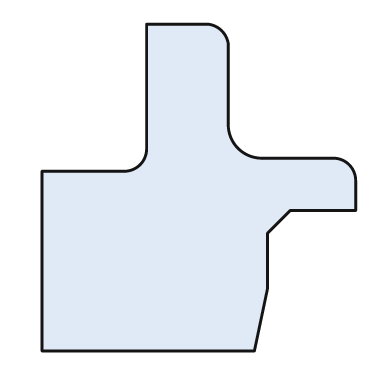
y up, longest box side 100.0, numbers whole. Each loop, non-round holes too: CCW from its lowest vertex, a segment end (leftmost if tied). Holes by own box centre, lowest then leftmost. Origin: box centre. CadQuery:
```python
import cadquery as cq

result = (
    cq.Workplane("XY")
    .moveTo(-48.0, -50.0)
    .lineTo(17.0, -50.0)
    .lineTo(21.0, -31.0)
    .lineTo(21.0, -14.0)
    .lineTo(28.0, -7.0)
    .lineTo(48.0, -7.0)
    .lineTo(48.0, 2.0)
    .threePointArc((46.0, 7.0), (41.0, 9.0))
    .lineTo(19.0, 9.0)
    .threePointArc((12.0, 12.0), (9.0, 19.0))
    .lineTo(9.0, 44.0)
    .threePointArc((7.0, 48.0), (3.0, 50.0))
    .lineTo(-16.0, 50.0)
    .lineTo(-16.0, 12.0)
    .threePointArc((-18.0, 7.0), (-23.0, 5.0))
    .lineTo(-48.0, 5.0)
    .close()
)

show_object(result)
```